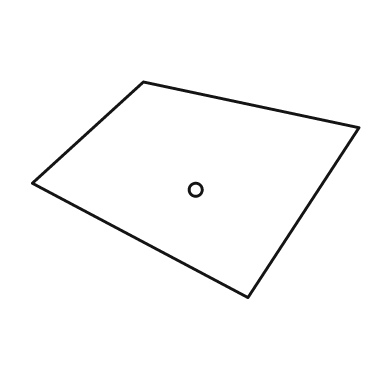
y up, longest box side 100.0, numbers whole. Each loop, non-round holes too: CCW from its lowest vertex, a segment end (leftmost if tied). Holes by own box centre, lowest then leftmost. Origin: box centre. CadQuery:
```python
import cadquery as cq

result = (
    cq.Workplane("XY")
    .moveTo(16.0, -33.0)
    .lineTo(50.0, 19.0)
    .lineTo(-16.0, 33.0)
    .lineTo(-50.0, 2.0)
    .close()
    .moveTo(0.0, 0.0)
    .circle(2.0)
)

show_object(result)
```